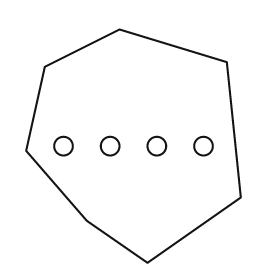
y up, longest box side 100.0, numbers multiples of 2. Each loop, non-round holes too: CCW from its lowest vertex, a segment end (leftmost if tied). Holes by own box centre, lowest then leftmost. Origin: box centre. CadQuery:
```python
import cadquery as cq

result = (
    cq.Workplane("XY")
    .moveTo(6.0, -50.0)
    .lineTo(46.0, -22.0)
    .lineTo(40.0, 36.0)
    .lineTo(-6.0, 50.0)
    .lineTo(-38.0, 34.0)
    .lineTo(-46.0, -2.0)
    .lineTo(-20.0, -32.0)
    .close()
    .moveTo(-30.0, 0.0)
    .circle(4.0)
    .moveTo(-10.0, 0.0)
    .circle(4.0)
    .moveTo(10.0, 0.0)
    .circle(4.0)
    .moveTo(30.0, 0.0)
    .circle(4.0)
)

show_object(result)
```